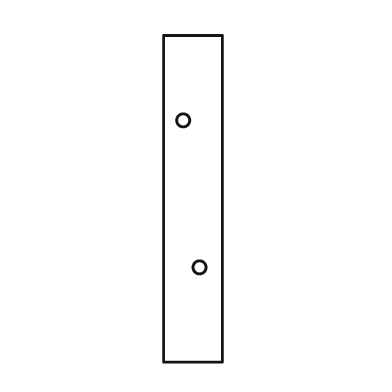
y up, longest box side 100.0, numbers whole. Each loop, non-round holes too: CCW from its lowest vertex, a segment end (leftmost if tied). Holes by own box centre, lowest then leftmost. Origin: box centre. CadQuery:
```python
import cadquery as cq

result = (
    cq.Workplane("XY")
    .moveTo(-9.0, -50.0)
    .lineTo(9.0, -50.0)
    .lineTo(9.0, 50.0)
    .lineTo(-9.0, 50.0)
    .close()
    .moveTo(2.0, -21.0)
    .circle(2.0)
    .moveTo(-3.0, 24.0)
    .circle(2.0)
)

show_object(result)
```